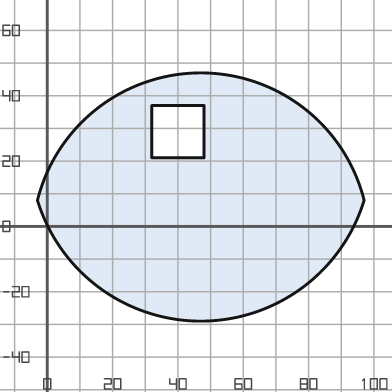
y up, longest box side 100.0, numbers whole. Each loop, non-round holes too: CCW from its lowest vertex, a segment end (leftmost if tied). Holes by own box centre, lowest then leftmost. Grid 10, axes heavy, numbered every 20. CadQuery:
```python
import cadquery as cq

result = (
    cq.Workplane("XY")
    .moveTo(-3.0, 8.0)
    .threePointArc((47.0, -29.0), (97.0, 8.0))
    .threePointArc((47.0, 47.0), (-3.0, 8.0))
    .close()
    .moveTo(32.0, 21.0)
    .lineTo(48.0, 21.0)
    .lineTo(48.0, 37.0)
    .lineTo(32.0, 37.0)
    .close()
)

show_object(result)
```